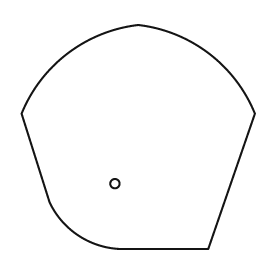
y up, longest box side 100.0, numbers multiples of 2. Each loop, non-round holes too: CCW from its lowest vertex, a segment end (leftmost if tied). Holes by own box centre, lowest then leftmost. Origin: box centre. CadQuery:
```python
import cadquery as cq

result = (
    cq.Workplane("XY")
    .moveTo(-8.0, -48.0)
    .lineTo(30.0, -48.0)
    .lineTo(50.0, 10.0)
    .threePointArc((30.0, 36.0), (0.0, 48.0))
    .threePointArc((-30.0, 36.0), (-50.0, 10.0))
    .lineTo(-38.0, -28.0)
    .threePointArc((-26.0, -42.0), (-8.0, -48.0))
    .close()
    .moveTo(-10.0, -20.0)
    .circle(2.0)
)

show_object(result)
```